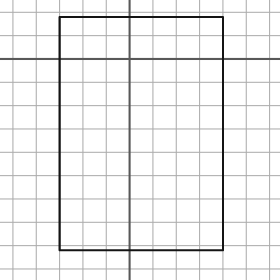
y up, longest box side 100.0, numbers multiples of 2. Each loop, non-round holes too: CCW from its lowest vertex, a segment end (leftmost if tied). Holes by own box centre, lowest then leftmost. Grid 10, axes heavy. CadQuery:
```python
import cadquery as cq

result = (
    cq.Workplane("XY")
    .moveTo(-30.0, -82.0)
    .lineTo(40.0, -82.0)
    .lineTo(40.0, 18.0)
    .lineTo(-30.0, 18.0)
    .close()
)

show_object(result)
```